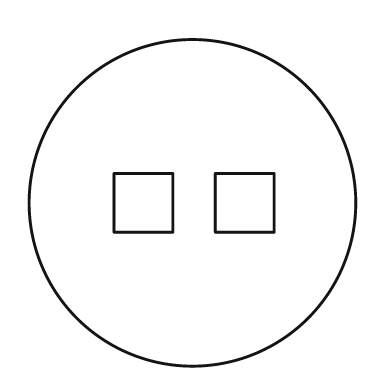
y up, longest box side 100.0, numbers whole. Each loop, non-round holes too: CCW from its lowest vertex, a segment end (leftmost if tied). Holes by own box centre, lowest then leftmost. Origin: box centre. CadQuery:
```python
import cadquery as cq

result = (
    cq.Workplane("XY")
    .moveTo(0.0, 0.0)
    .circle(50.0)
    .moveTo(-24.0, -9.0)
    .lineTo(-6.0, -9.0)
    .lineTo(-6.0, 9.0)
    .lineTo(-24.0, 9.0)
    .close()
    .moveTo(7.0, -9.0)
    .lineTo(25.0, -9.0)
    .lineTo(25.0, 9.0)
    .lineTo(7.0, 9.0)
    .close()
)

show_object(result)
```